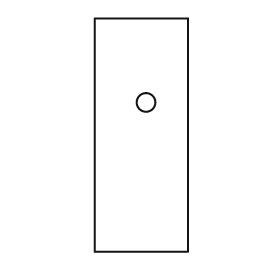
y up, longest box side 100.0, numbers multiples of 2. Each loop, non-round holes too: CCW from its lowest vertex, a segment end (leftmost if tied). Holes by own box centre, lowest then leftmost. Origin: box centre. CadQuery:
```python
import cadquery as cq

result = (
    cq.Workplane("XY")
    .moveTo(-20.0, -50.0)
    .lineTo(20.0, -50.0)
    .lineTo(20.0, 50.0)
    .lineTo(-20.0, 50.0)
    .close()
    .moveTo(2.0, 14.0)
    .circle(4.0)
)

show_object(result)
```